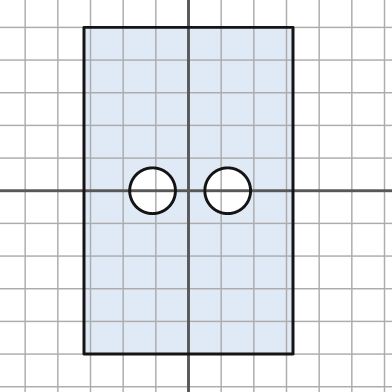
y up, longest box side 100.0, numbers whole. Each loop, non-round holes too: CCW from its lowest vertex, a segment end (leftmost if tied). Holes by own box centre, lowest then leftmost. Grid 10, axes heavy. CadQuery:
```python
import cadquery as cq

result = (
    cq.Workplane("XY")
    .moveTo(-32.0, -50.0)
    .lineTo(32.0, -50.0)
    .lineTo(32.0, 50.0)
    .lineTo(-32.0, 50.0)
    .close()
    .moveTo(-11.0, 0.0)
    .circle(7.0)
    .moveTo(12.0, 0.0)
    .circle(7.0)
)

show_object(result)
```